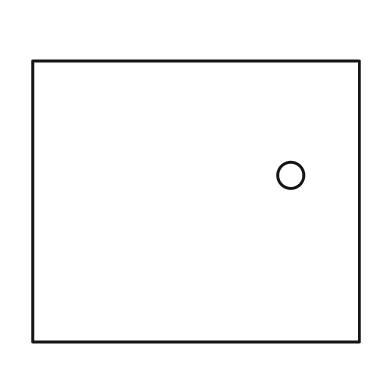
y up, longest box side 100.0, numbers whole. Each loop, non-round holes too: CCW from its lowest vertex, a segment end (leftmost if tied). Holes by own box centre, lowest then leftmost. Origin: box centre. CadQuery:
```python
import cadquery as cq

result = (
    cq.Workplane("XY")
    .moveTo(-50.0, -43.0)
    .lineTo(50.0, -43.0)
    .lineTo(50.0, 43.0)
    .lineTo(-50.0, 43.0)
    .close()
    .moveTo(29.0, 8.0)
    .circle(4.0)
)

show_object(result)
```